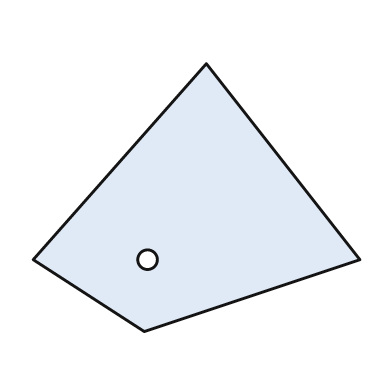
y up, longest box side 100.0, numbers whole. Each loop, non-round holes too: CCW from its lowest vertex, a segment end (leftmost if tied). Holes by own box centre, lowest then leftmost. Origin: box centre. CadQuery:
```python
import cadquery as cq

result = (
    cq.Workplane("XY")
    .moveTo(-16.0, -41.0)
    .lineTo(50.0, -19.0)
    .lineTo(3.0, 41.0)
    .lineTo(-50.0, -19.0)
    .close()
    .moveTo(-15.0, -19.0)
    .circle(3.0)
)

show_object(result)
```